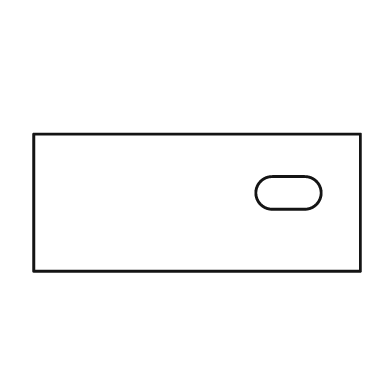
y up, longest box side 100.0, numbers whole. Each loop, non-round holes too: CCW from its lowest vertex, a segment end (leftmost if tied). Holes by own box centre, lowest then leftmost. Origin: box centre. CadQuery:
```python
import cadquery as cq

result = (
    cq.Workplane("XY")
    .moveTo(-50.0, -21.0)
    .lineTo(50.0, -21.0)
    .lineTo(50.0, 21.0)
    .lineTo(-50.0, 21.0)
    .close()
    .moveTo(23.0, -2.0)
    .lineTo(33.0, -2.0)
    .threePointArc((38.0, 3.0), (33.0, 8.0))
    .lineTo(23.0, 8.0)
    .threePointArc((18.0, 3.0), (23.0, -2.0))
    .close()
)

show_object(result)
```